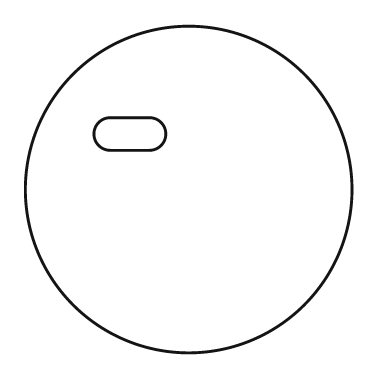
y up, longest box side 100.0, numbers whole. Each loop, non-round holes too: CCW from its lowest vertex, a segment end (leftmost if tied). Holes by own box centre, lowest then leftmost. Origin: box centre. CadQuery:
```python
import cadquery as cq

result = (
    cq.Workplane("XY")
    .moveTo(0.0, 0.0)
    .circle(50.0)
    .moveTo(-24.0, 12.0)
    .lineTo(-12.0, 12.0)
    .threePointArc((-7.0, 17.0), (-12.0, 22.0))
    .lineTo(-24.0, 22.0)
    .threePointArc((-29.0, 17.0), (-24.0, 12.0))
    .close()
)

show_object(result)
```